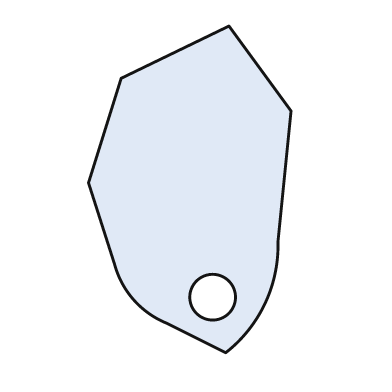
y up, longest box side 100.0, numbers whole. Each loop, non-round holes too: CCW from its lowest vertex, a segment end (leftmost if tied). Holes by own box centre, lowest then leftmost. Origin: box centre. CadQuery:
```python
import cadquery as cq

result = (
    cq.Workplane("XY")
    .moveTo(11.0, -50.0)
    .threePointArc((23.0, -35.0), (27.0, -16.0))
    .lineTo(31.0, 24.0)
    .lineTo(12.0, 50.0)
    .lineTo(-21.0, 34.0)
    .lineTo(-31.0, 2.0)
    .lineTo(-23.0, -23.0)
    .threePointArc((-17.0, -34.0), (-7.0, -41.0))
    .close()
    .moveTo(7.0, -33.0)
    .circle(7.0)
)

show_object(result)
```